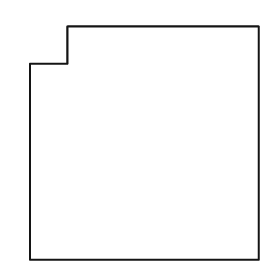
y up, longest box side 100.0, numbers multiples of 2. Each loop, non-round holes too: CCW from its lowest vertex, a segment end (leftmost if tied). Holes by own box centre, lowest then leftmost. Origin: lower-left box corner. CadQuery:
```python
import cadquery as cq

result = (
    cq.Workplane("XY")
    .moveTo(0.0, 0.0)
    .lineTo(98.0, 0.0)
    .lineTo(98.0, 100.0)
    .lineTo(16.0, 100.0)
    .lineTo(16.0, 84.0)
    .lineTo(0.0, 84.0)
    .close()
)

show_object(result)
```